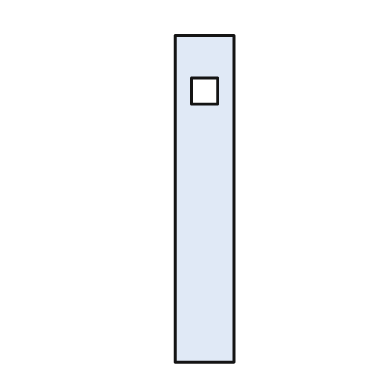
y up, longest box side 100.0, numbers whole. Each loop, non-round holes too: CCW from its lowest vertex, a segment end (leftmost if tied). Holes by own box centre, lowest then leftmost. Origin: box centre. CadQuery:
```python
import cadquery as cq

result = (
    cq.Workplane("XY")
    .moveTo(-9.0, -50.0)
    .lineTo(9.0, -50.0)
    .lineTo(9.0, 50.0)
    .lineTo(-9.0, 50.0)
    .close()
    .moveTo(-4.0, 29.0)
    .lineTo(4.0, 29.0)
    .lineTo(4.0, 37.0)
    .lineTo(-4.0, 37.0)
    .close()
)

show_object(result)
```